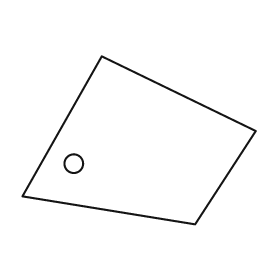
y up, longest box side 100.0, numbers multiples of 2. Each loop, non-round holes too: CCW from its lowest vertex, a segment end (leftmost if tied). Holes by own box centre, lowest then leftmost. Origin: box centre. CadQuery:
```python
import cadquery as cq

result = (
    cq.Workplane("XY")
    .moveTo(24.0, -36.0)
    .lineTo(50.0, 4.0)
    .lineTo(-16.0, 36.0)
    .lineTo(-50.0, -24.0)
    .close()
    .moveTo(-28.0, -10.0)
    .circle(4.0)
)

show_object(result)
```